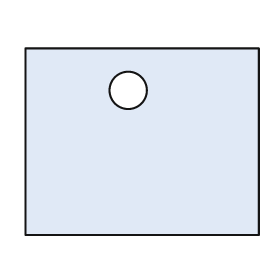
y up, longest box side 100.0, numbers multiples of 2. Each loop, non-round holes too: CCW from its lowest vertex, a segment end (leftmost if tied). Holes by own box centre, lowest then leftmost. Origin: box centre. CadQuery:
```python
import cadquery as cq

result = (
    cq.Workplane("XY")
    .moveTo(-50.0, -40.0)
    .lineTo(50.0, -40.0)
    .lineTo(50.0, 40.0)
    .lineTo(-50.0, 40.0)
    .close()
    .moveTo(-6.0, 22.0)
    .circle(8.0)
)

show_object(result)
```